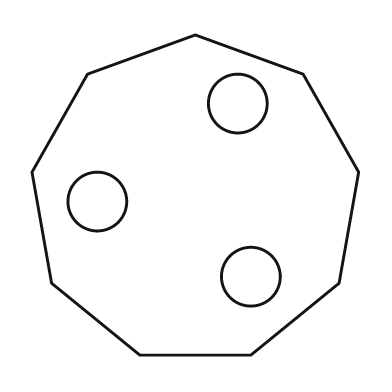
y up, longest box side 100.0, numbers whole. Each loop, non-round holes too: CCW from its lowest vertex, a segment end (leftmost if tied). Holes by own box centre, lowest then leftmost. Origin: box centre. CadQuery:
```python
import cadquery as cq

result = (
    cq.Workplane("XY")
    .moveTo(-17.0, -49.0)
    .lineTo(17.0, -49.0)
    .lineTo(44.0, -27.0)
    .lineTo(50.0, 7.0)
    .lineTo(33.0, 37.0)
    .lineTo(0.0, 49.0)
    .lineTo(-33.0, 37.0)
    .lineTo(-50.0, 7.0)
    .lineTo(-44.0, -27.0)
    .close()
    .moveTo(17.0, -25.0)
    .circle(9.0)
    .moveTo(-30.0, -2.0)
    .circle(9.0)
    .moveTo(13.0, 28.0)
    .circle(9.0)
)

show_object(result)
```